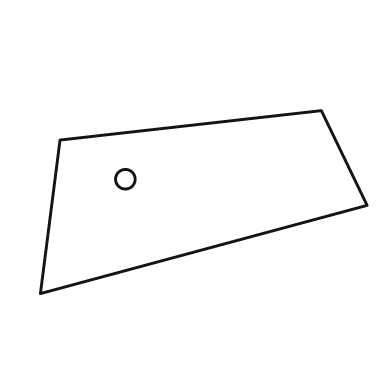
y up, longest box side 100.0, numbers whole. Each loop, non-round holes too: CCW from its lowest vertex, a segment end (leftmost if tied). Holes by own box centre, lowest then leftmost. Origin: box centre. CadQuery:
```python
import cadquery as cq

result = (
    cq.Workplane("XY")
    .moveTo(-50.0, -28.0)
    .lineTo(50.0, -1.0)
    .lineTo(36.0, 28.0)
    .lineTo(-44.0, 19.0)
    .close()
    .moveTo(-24.0, 7.0)
    .circle(3.0)
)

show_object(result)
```